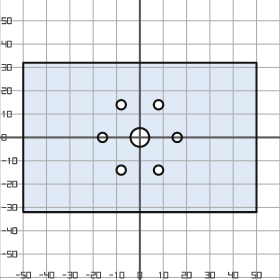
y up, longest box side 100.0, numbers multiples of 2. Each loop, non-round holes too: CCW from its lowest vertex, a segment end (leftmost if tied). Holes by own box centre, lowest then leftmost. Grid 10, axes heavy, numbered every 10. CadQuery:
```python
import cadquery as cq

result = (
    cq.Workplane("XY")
    .moveTo(-50.0, -32.0)
    .lineTo(50.0, -32.0)
    .lineTo(50.0, 32.0)
    .lineTo(-50.0, 32.0)
    .close()
    .moveTo(-8.0, -14.0)
    .circle(2.0)
    .moveTo(8.0, -14.0)
    .circle(2.0)
    .moveTo(-16.0, 0.0)
    .circle(2.0)
    .moveTo(0.0, 0.0)
    .circle(4.0)
    .moveTo(16.0, 0.0)
    .circle(2.0)
    .moveTo(-8.0, 14.0)
    .circle(2.0)
    .moveTo(8.0, 14.0)
    .circle(2.0)
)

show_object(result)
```